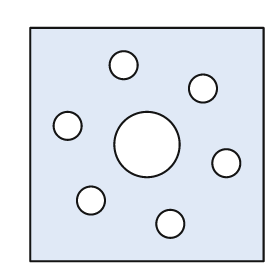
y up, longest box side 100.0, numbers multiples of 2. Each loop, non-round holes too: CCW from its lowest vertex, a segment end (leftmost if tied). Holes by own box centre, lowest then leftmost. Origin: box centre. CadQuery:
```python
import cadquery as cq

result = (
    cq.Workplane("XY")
    .moveTo(-50.0, -50.0)
    .lineTo(50.0, -50.0)
    .lineTo(50.0, 50.0)
    .lineTo(-50.0, 50.0)
    .close()
    .moveTo(10.0, -34.0)
    .circle(6.0)
    .moveTo(-24.0, -24.0)
    .circle(6.0)
    .moveTo(34.0, -8.0)
    .circle(6.0)
    .moveTo(0.0, 0.0)
    .circle(14.0)
    .moveTo(-34.0, 8.0)
    .circle(6.0)
    .moveTo(24.0, 24.0)
    .circle(6.0)
    .moveTo(-10.0, 34.0)
    .circle(6.0)
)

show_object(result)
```